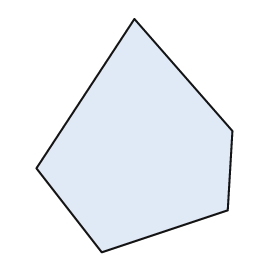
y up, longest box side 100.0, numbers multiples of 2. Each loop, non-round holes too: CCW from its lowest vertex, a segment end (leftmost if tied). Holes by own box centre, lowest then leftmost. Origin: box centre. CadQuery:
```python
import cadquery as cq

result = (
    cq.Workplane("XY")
    .moveTo(-14.0, -50.0)
    .lineTo(40.0, -32.0)
    .lineTo(42.0, 2.0)
    .lineTo(0.0, 50.0)
    .lineTo(-42.0, -14.0)
    .close()
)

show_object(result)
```